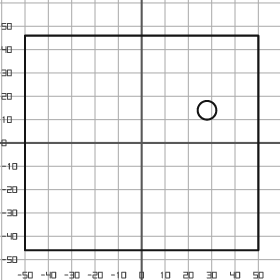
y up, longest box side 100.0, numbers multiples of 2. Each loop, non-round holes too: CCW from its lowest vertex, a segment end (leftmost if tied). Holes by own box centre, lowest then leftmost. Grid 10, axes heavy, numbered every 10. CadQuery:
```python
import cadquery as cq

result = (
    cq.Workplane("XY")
    .moveTo(-50.0, -46.0)
    .lineTo(50.0, -46.0)
    .lineTo(50.0, 46.0)
    .lineTo(-50.0, 46.0)
    .close()
    .moveTo(28.0, 14.0)
    .circle(4.0)
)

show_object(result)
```